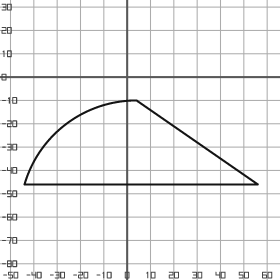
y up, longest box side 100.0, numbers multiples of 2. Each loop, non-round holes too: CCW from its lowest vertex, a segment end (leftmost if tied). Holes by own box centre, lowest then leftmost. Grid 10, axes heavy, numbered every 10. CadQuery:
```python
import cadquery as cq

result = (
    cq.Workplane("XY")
    .moveTo(-44.0, -46.0)
    .lineTo(56.0, -46.0)
    .lineTo(4.0, -10.0)
    .threePointArc((-26.0, -20.0), (-44.0, -46.0))
    .close()
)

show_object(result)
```